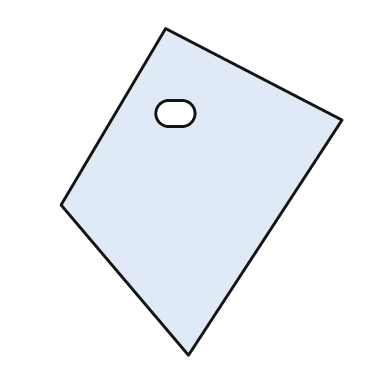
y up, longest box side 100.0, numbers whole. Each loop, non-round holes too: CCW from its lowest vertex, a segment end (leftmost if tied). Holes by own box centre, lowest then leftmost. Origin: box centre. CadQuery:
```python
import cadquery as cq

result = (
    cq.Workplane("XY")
    .moveTo(-4.0, -50.0)
    .lineTo(43.0, 22.0)
    .lineTo(-11.0, 50.0)
    .lineTo(-43.0, -4.0)
    .close()
    .moveTo(-10.0, 20.0)
    .lineTo(-6.0, 20.0)
    .threePointArc((-2.0, 24.0), (-6.0, 28.0))
    .lineTo(-10.0, 28.0)
    .threePointArc((-14.0, 24.0), (-10.0, 20.0))
    .close()
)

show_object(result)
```